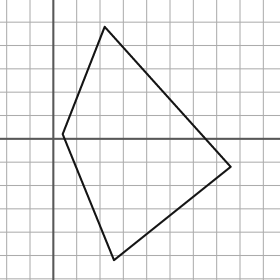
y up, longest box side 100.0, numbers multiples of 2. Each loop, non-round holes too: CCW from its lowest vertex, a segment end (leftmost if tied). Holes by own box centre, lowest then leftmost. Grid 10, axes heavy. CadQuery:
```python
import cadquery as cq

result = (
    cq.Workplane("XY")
    .moveTo(26.0, -52.0)
    .lineTo(76.0, -12.0)
    .lineTo(22.0, 48.0)
    .lineTo(4.0, 2.0)
    .close()
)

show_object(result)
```